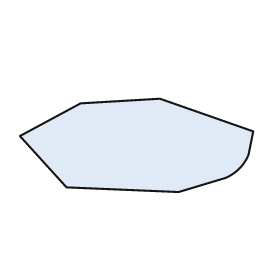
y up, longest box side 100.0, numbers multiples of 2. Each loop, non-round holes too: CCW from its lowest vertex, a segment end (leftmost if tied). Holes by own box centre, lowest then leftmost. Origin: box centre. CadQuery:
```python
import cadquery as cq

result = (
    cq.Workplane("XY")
    .moveTo(18.0, -20.0)
    .lineTo(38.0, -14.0)
    .threePointArc((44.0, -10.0), (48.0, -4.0))
    .lineTo(50.0, 6.0)
    .lineTo(10.0, 20.0)
    .lineTo(-24.0, 18.0)
    .lineTo(-50.0, 4.0)
    .lineTo(-30.0, -18.0)
    .close()
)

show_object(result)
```